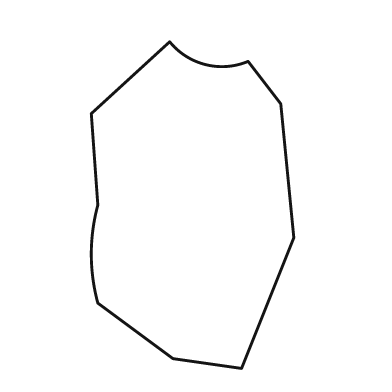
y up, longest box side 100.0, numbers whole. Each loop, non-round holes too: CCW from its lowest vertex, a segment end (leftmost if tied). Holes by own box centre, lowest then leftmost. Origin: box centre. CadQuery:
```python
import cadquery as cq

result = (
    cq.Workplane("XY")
    .moveTo(15.0, -50.0)
    .lineTo(31.0, -10.0)
    .lineTo(27.0, 31.0)
    .lineTo(17.0, 44.0)
    .threePointArc((4.0, 43.0), (-7.0, 50.0))
    .lineTo(-31.0, 28.0)
    .lineTo(-29.0, 0.0)
    .threePointArc((-31.0, -15.0), (-29.0, -30.0))
    .lineTo(-6.0, -47.0)
    .close()
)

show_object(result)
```